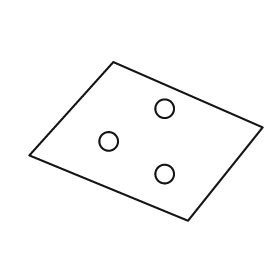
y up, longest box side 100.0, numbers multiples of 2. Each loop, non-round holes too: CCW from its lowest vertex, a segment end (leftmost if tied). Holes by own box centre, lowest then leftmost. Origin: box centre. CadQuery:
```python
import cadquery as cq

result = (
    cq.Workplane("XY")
    .moveTo(18.0, -34.0)
    .lineTo(50.0, 6.0)
    .lineTo(-14.0, 34.0)
    .lineTo(-50.0, -6.0)
    .close()
    .moveTo(8.0, -14.0)
    .circle(4.0)
    .moveTo(-16.0, 0.0)
    .circle(4.0)
    .moveTo(8.0, 14.0)
    .circle(4.0)
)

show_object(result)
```